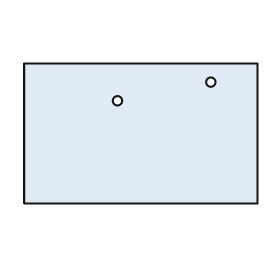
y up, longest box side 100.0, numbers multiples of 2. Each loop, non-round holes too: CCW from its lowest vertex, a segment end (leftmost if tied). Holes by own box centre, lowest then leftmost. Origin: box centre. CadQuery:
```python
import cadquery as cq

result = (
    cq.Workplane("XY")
    .moveTo(-50.0, -30.0)
    .lineTo(50.0, -30.0)
    .lineTo(50.0, 30.0)
    .lineTo(-50.0, 30.0)
    .close()
    .moveTo(-10.0, 14.0)
    .circle(2.0)
    .moveTo(30.0, 22.0)
    .circle(2.0)
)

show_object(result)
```